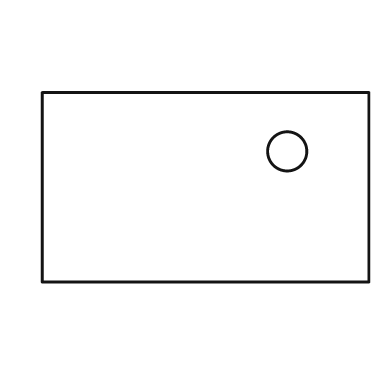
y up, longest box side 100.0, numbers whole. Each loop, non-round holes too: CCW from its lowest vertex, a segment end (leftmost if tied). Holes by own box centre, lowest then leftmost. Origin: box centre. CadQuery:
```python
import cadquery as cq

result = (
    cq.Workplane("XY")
    .moveTo(-50.0, -29.0)
    .lineTo(50.0, -29.0)
    .lineTo(50.0, 29.0)
    .lineTo(-50.0, 29.0)
    .close()
    .moveTo(25.0, 11.0)
    .circle(6.0)
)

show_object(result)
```